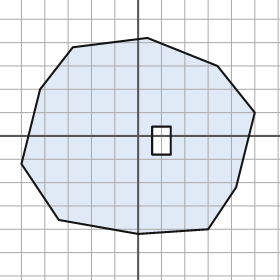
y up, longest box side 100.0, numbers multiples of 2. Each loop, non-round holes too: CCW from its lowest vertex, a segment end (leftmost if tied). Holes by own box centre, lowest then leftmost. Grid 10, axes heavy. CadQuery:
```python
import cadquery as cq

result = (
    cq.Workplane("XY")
    .moveTo(0.0, -42.0)
    .lineTo(30.0, -40.0)
    .lineTo(42.0, -22.0)
    .lineTo(50.0, 10.0)
    .lineTo(34.0, 30.0)
    .lineTo(4.0, 42.0)
    .lineTo(-28.0, 38.0)
    .lineTo(-42.0, 20.0)
    .lineTo(-50.0, -12.0)
    .lineTo(-34.0, -36.0)
    .close()
    .moveTo(6.0, -8.0)
    .lineTo(14.0, -8.0)
    .lineTo(14.0, 4.0)
    .lineTo(6.0, 4.0)
    .close()
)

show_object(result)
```